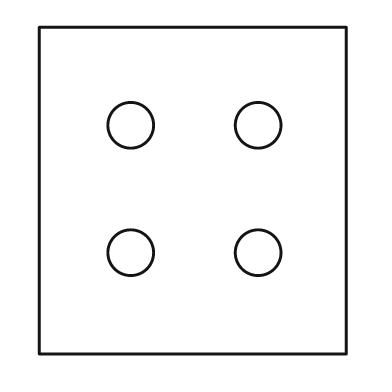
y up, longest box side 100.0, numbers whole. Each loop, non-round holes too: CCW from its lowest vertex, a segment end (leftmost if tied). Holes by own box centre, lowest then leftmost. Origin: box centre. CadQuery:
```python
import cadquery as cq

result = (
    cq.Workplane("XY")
    .moveTo(-47.0, -50.0)
    .lineTo(47.0, -50.0)
    .lineTo(47.0, 50.0)
    .lineTo(-47.0, 50.0)
    .close()
    .moveTo(-19.0, -19.0)
    .circle(7.0)
    .moveTo(20.0, -19.0)
    .circle(7.0)
    .moveTo(-19.0, 20.0)
    .circle(7.0)
    .moveTo(20.0, 20.0)
    .circle(7.0)
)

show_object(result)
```